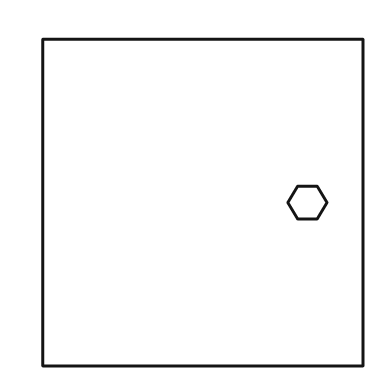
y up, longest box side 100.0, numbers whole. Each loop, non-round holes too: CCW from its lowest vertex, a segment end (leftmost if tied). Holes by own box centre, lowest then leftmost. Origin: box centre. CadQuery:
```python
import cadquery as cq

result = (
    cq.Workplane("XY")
    .moveTo(-49.0, -50.0)
    .lineTo(49.0, -50.0)
    .lineTo(49.0, 50.0)
    .lineTo(-49.0, 50.0)
    .close()
    .moveTo(29.0, -5.0)
    .lineTo(35.0, -5.0)
    .lineTo(38.0, 0.0)
    .lineTo(35.0, 5.0)
    .lineTo(29.0, 5.0)
    .lineTo(26.0, 0.0)
    .close()
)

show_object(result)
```